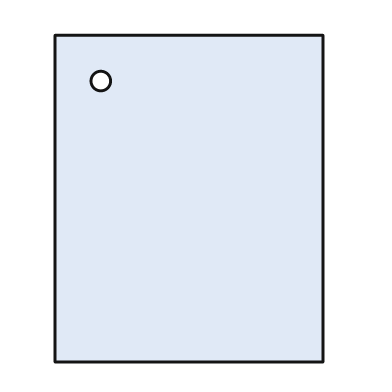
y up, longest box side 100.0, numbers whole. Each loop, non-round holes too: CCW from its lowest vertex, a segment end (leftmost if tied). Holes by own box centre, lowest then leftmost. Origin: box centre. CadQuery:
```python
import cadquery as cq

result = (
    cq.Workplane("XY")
    .moveTo(-41.0, -50.0)
    .lineTo(41.0, -50.0)
    .lineTo(41.0, 50.0)
    .lineTo(-41.0, 50.0)
    .close()
    .moveTo(-27.0, 36.0)
    .circle(3.0)
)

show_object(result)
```